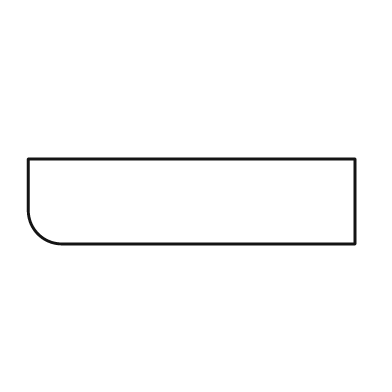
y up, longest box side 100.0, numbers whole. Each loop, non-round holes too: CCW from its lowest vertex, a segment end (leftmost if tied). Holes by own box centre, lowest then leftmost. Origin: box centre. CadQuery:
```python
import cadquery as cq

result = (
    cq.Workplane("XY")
    .moveTo(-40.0, -13.0)
    .lineTo(50.0, -13.0)
    .lineTo(50.0, 13.0)
    .lineTo(-50.0, 13.0)
    .lineTo(-50.0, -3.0)
    .threePointArc((-47.0, -10.0), (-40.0, -13.0))
    .close()
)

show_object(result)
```